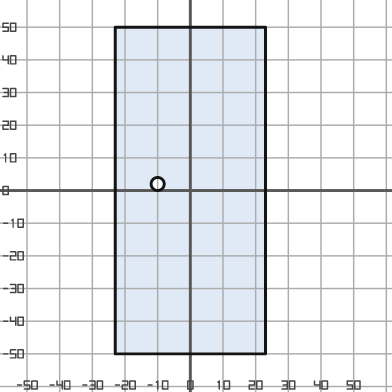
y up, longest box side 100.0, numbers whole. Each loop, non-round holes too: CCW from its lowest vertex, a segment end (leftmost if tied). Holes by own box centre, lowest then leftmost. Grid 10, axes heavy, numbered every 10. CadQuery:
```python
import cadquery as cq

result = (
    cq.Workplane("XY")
    .moveTo(-23.0, -50.0)
    .lineTo(23.0, -50.0)
    .lineTo(23.0, 50.0)
    .lineTo(-23.0, 50.0)
    .close()
    .moveTo(-10.0, 2.0)
    .circle(2.0)
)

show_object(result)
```